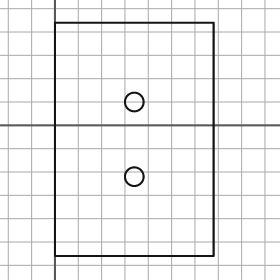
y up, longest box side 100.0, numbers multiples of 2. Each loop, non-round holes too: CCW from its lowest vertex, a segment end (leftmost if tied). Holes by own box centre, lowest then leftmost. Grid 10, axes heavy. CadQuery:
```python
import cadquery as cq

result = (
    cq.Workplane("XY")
    .moveTo(0.0, -56.0)
    .lineTo(68.0, -56.0)
    .lineTo(68.0, 44.0)
    .lineTo(0.0, 44.0)
    .close()
    .moveTo(34.0, -22.0)
    .circle(4.0)
    .moveTo(34.0, 10.0)
    .circle(4.0)
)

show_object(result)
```